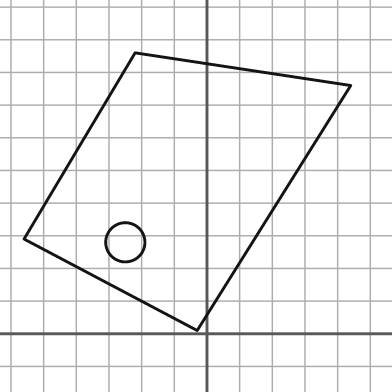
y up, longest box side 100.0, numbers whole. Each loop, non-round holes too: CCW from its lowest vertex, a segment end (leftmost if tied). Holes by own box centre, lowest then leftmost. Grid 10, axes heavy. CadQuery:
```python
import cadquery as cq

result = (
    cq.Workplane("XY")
    .moveTo(-3.0, 1.0)
    .lineTo(44.0, 76.0)
    .lineTo(-22.0, 86.0)
    .lineTo(-56.0, 29.0)
    .close()
    .moveTo(-25.0, 28.0)
    .circle(6.0)
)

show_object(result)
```